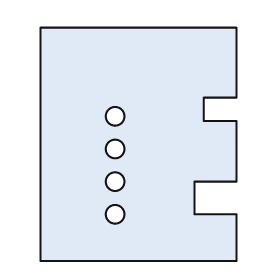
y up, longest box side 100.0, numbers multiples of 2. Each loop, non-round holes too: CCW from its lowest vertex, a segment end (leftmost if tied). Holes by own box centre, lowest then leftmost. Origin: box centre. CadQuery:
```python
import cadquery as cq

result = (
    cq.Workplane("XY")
    .moveTo(-42.0, -50.0)
    .lineTo(42.0, -50.0)
    .lineTo(42.0, -30.0)
    .lineTo(24.0, -30.0)
    .lineTo(24.0, -16.0)
    .lineTo(42.0, -16.0)
    .lineTo(42.0, 10.0)
    .lineTo(28.0, 10.0)
    .lineTo(28.0, 20.0)
    .lineTo(42.0, 20.0)
    .lineTo(42.0, 50.0)
    .lineTo(-42.0, 50.0)
    .close()
    .moveTo(-10.0, -30.0)
    .circle(4.0)
    .moveTo(-10.0, -16.0)
    .circle(4.0)
    .moveTo(-10.0, -2.0)
    .circle(4.0)
    .moveTo(-10.0, 12.0)
    .circle(4.0)
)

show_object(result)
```